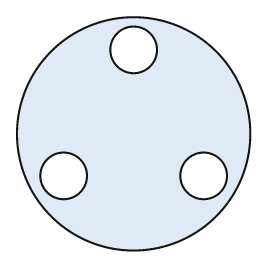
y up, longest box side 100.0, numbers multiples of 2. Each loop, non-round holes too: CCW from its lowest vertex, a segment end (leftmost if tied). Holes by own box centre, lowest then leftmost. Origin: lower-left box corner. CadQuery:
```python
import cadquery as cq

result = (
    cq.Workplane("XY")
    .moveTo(50.0, 50.0)
    .circle(50.0)
    .moveTo(20.0, 32.0)
    .circle(10.0)
    .moveTo(80.0, 32.0)
    .circle(10.0)
    .moveTo(50.0, 86.0)
    .circle(10.0)
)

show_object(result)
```